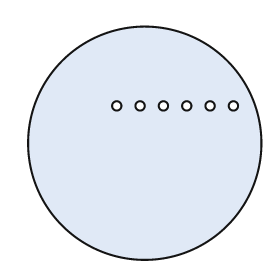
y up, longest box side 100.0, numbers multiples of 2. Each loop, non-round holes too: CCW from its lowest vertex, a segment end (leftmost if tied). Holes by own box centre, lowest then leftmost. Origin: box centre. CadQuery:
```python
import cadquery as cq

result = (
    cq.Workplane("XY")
    .moveTo(0.0, 0.0)
    .circle(50.0)
    .moveTo(-12.0, 16.0)
    .circle(2.0)
    .moveTo(-2.0, 16.0)
    .circle(2.0)
    .moveTo(8.0, 16.0)
    .circle(2.0)
    .moveTo(18.0, 16.0)
    .circle(2.0)
    .moveTo(28.0, 16.0)
    .circle(2.0)
    .moveTo(38.0, 16.0)
    .circle(2.0)
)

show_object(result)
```